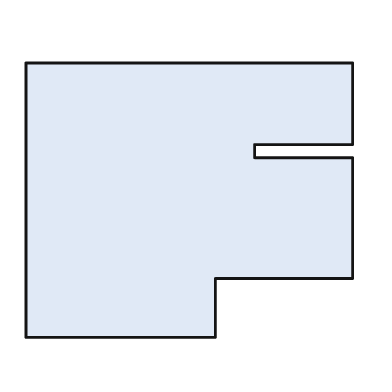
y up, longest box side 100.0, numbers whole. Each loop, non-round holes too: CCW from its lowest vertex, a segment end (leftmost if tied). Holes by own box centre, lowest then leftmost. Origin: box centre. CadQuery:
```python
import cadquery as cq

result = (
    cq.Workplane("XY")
    .moveTo(-50.0, -42.0)
    .lineTo(8.0, -42.0)
    .lineTo(8.0, -24.0)
    .lineTo(50.0, -24.0)
    .lineTo(50.0, 13.0)
    .lineTo(20.0, 13.0)
    .lineTo(20.0, 17.0)
    .lineTo(50.0, 17.0)
    .lineTo(50.0, 42.0)
    .lineTo(-50.0, 42.0)
    .close()
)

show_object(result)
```